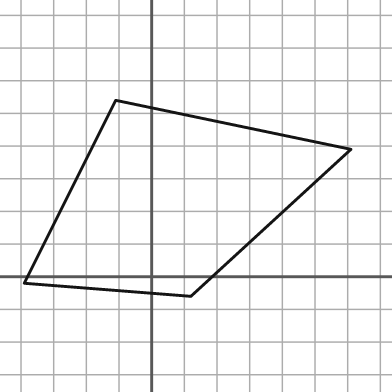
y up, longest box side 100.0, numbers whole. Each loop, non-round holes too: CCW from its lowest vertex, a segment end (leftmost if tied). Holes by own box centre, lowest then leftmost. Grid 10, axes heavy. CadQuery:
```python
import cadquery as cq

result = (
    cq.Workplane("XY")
    .moveTo(12.0, -6.0)
    .lineTo(61.0, 39.0)
    .lineTo(-11.0, 54.0)
    .lineTo(-39.0, -2.0)
    .close()
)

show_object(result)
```